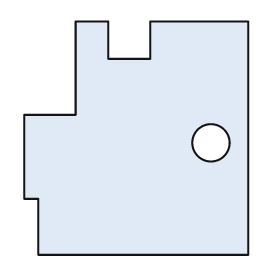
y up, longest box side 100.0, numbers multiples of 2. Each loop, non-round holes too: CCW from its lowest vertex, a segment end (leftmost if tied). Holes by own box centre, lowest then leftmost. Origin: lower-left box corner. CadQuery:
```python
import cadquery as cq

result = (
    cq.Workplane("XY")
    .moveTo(6.0, 0.0)
    .lineTo(96.0, 0.0)
    .lineTo(96.0, 100.0)
    .lineTo(54.0, 100.0)
    .lineTo(54.0, 84.0)
    .lineTo(36.0, 84.0)
    .lineTo(36.0, 100.0)
    .lineTo(22.0, 100.0)
    .lineTo(22.0, 60.0)
    .lineTo(0.0, 60.0)
    .lineTo(0.0, 24.0)
    .lineTo(6.0, 24.0)
    .close()
    .moveTo(80.0, 48.0)
    .circle(8.0)
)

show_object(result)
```